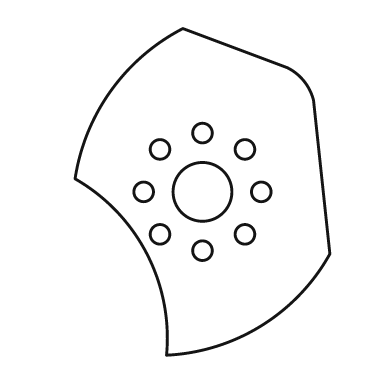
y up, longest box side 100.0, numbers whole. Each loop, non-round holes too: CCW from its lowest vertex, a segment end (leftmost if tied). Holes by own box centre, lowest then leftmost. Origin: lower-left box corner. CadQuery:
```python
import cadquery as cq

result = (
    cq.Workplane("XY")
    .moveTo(28.0, 0.0)
    .threePointArc((57.0, 9.0), (78.0, 31.0))
    .lineTo(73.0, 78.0)
    .threePointArc((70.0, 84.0), (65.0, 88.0))
    .lineTo(33.0, 100.0)
    .threePointArc((11.0, 81.0), (0.0, 54.0))
    .threePointArc((22.0, 31.0), (28.0, 0.0))
    .close()
    .moveTo(39.0, 32.0)
    .circle(3.0)
    .moveTo(26.0, 37.0)
    .circle(3.0)
    .moveTo(52.0, 37.0)
    .circle(3.0)
    .moveTo(21.0, 50.0)
    .circle(3.0)
    .moveTo(39.0, 50.0)
    .circle(9.0)
    .moveTo(57.0, 50.0)
    .circle(3.0)
    .moveTo(26.0, 63.0)
    .circle(3.0)
    .moveTo(52.0, 63.0)
    .circle(3.0)
    .moveTo(39.0, 68.0)
    .circle(3.0)
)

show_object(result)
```